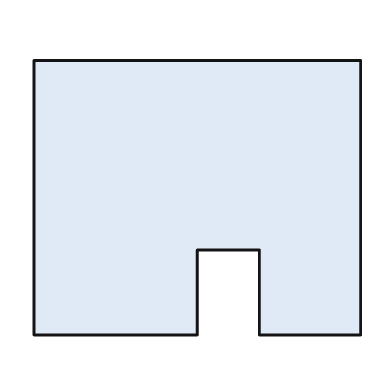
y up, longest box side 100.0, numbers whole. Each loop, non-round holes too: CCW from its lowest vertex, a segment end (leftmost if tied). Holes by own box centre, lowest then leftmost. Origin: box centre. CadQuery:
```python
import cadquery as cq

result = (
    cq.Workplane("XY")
    .moveTo(-50.0, -42.0)
    .lineTo(0.0, -42.0)
    .lineTo(0.0, -16.0)
    .lineTo(19.0, -16.0)
    .lineTo(19.0, -42.0)
    .lineTo(50.0, -42.0)
    .lineTo(50.0, 42.0)
    .lineTo(-50.0, 42.0)
    .close()
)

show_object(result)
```